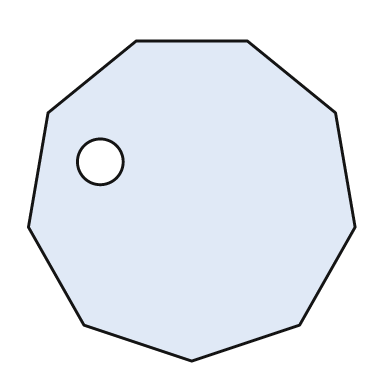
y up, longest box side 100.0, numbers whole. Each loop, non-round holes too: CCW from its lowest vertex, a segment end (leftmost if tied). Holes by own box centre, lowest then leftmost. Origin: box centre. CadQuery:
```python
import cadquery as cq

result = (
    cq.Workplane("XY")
    .moveTo(0.0, -49.0)
    .lineTo(33.0, -38.0)
    .lineTo(50.0, -8.0)
    .lineTo(44.0, 27.0)
    .lineTo(17.0, 49.0)
    .lineTo(-17.0, 49.0)
    .lineTo(-44.0, 27.0)
    .lineTo(-50.0, -8.0)
    .lineTo(-33.0, -38.0)
    .close()
    .moveTo(-28.0, 12.0)
    .circle(7.0)
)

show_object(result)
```